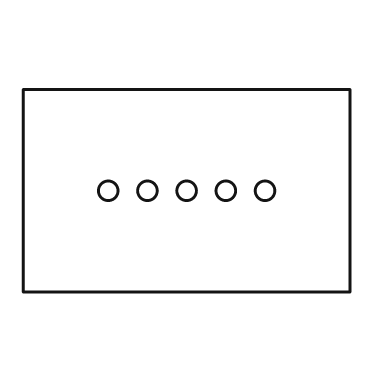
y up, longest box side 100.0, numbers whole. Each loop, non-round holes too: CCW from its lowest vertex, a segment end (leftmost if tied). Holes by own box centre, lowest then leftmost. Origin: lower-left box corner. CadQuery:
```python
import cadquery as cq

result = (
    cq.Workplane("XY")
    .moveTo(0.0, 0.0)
    .lineTo(100.0, 0.0)
    .lineTo(100.0, 62.0)
    .lineTo(0.0, 62.0)
    .close()
    .moveTo(26.0, 31.0)
    .circle(3.0)
    .moveTo(38.0, 31.0)
    .circle(3.0)
    .moveTo(50.0, 31.0)
    .circle(3.0)
    .moveTo(62.0, 31.0)
    .circle(3.0)
    .moveTo(74.0, 31.0)
    .circle(3.0)
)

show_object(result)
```